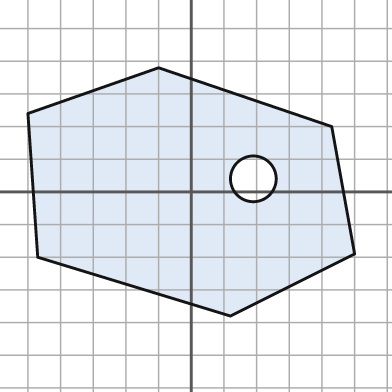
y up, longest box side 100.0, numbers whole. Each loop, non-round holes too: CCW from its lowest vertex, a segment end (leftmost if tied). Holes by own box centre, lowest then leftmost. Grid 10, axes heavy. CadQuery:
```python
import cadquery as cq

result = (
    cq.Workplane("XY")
    .moveTo(12.0, -38.0)
    .lineTo(50.0, -19.0)
    .lineTo(43.0, 20.0)
    .lineTo(-10.0, 38.0)
    .lineTo(-50.0, 24.0)
    .lineTo(-47.0, -20.0)
    .close()
    .moveTo(19.0, 4.0)
    .circle(7.0)
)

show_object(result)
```